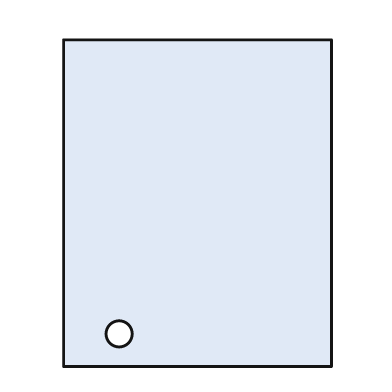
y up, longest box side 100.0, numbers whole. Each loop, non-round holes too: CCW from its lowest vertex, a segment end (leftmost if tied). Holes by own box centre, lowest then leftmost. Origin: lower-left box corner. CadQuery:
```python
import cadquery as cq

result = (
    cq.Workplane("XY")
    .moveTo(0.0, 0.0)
    .lineTo(82.0, 0.0)
    .lineTo(82.0, 100.0)
    .lineTo(0.0, 100.0)
    .close()
    .moveTo(17.0, 10.0)
    .circle(4.0)
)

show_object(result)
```